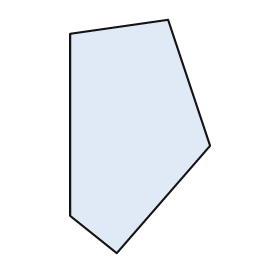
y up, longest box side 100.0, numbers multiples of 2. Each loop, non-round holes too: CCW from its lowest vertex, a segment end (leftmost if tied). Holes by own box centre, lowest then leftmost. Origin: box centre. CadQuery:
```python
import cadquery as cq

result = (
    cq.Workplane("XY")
    .moveTo(-10.0, -50.0)
    .lineTo(30.0, -4.0)
    .lineTo(12.0, 50.0)
    .lineTo(-30.0, 44.0)
    .lineTo(-30.0, -34.0)
    .close()
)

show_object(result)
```